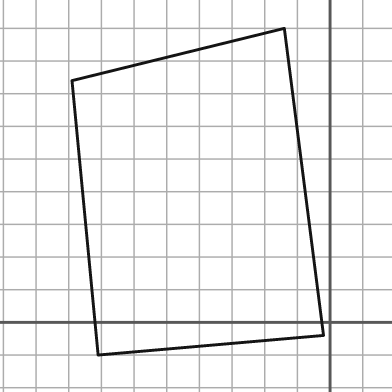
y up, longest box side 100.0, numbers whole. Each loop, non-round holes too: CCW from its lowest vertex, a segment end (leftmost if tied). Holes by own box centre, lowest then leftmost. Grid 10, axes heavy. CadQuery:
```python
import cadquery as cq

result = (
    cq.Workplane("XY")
    .moveTo(-71.0, -10.0)
    .lineTo(-2.0, -4.0)
    .lineTo(-14.0, 90.0)
    .lineTo(-79.0, 74.0)
    .close()
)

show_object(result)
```